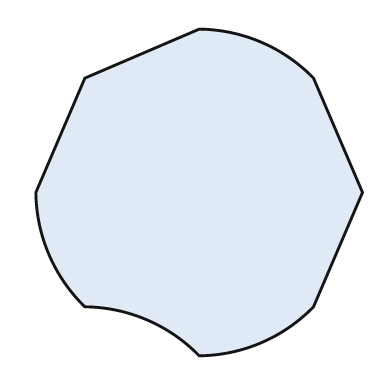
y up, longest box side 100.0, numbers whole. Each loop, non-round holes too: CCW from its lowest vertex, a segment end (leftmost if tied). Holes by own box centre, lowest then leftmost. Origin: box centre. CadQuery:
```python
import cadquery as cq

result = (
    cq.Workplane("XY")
    .moveTo(0.0, -50.0)
    .threePointArc((19.0, -46.0), (35.0, -35.0))
    .lineTo(50.0, 0.0)
    .lineTo(35.0, 35.0)
    .threePointArc((19.0, 46.0), (0.0, 50.0))
    .lineTo(-35.0, 35.0)
    .lineTo(-50.0, 0.0)
    .threePointArc((-46.0, -19.0), (-35.0, -35.0))
    .threePointArc((-16.0, -39.0), (0.0, -50.0))
    .close()
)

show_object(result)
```